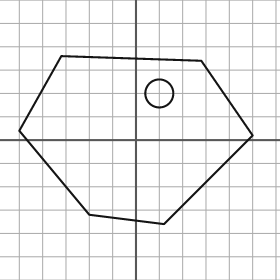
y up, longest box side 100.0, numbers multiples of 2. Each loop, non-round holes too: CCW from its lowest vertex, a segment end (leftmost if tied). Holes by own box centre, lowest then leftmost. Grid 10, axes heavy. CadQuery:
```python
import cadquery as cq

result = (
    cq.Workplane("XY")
    .moveTo(12.0, -36.0)
    .lineTo(50.0, 2.0)
    .lineTo(28.0, 34.0)
    .lineTo(-32.0, 36.0)
    .lineTo(-50.0, 4.0)
    .lineTo(-20.0, -32.0)
    .close()
    .moveTo(10.0, 20.0)
    .circle(6.0)
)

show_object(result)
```